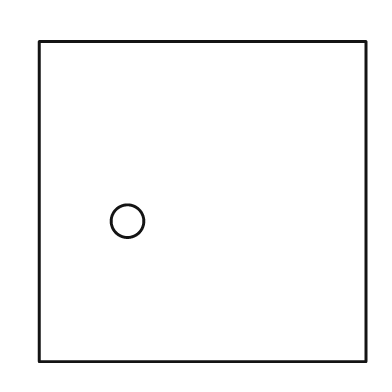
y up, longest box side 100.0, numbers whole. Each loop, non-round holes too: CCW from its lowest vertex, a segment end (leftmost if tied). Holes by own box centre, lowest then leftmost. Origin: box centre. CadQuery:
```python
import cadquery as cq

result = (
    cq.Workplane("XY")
    .moveTo(-50.0, -49.0)
    .lineTo(50.0, -49.0)
    .lineTo(50.0, 49.0)
    .lineTo(-50.0, 49.0)
    .close()
    .moveTo(-23.0, -6.0)
    .circle(5.0)
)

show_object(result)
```